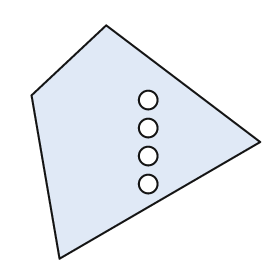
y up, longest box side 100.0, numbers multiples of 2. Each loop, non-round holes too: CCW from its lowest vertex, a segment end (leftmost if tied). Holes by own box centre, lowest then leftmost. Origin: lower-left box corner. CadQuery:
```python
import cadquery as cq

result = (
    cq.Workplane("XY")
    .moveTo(12.0, 0.0)
    .lineTo(98.0, 50.0)
    .lineTo(32.0, 100.0)
    .lineTo(0.0, 70.0)
    .close()
    .moveTo(50.0, 32.0)
    .circle(4.0)
    .moveTo(50.0, 44.0)
    .circle(4.0)
    .moveTo(50.0, 56.0)
    .circle(4.0)
    .moveTo(50.0, 68.0)
    .circle(4.0)
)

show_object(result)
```